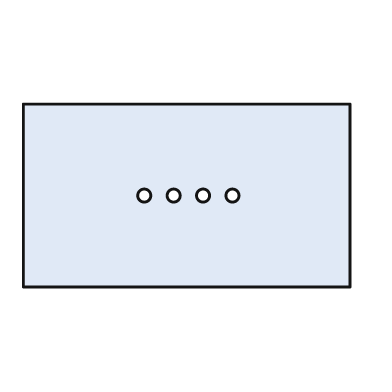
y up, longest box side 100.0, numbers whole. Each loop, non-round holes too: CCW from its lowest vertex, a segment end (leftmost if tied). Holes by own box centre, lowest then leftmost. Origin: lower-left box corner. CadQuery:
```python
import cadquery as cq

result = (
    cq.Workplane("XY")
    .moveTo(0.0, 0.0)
    .lineTo(100.0, 0.0)
    .lineTo(100.0, 56.0)
    .lineTo(0.0, 56.0)
    .close()
    .moveTo(37.0, 28.0)
    .circle(2.0)
    .moveTo(46.0, 28.0)
    .circle(2.0)
    .moveTo(55.0, 28.0)
    .circle(2.0)
    .moveTo(64.0, 28.0)
    .circle(2.0)
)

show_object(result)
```